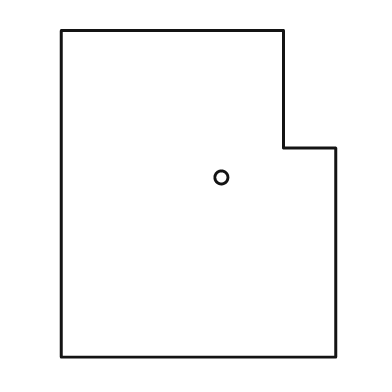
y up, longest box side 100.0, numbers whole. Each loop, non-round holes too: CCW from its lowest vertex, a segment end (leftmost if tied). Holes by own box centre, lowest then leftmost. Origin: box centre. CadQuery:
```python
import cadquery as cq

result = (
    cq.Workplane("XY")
    .moveTo(-42.0, -50.0)
    .lineTo(42.0, -50.0)
    .lineTo(42.0, 14.0)
    .lineTo(26.0, 14.0)
    .lineTo(26.0, 50.0)
    .lineTo(-42.0, 50.0)
    .close()
    .moveTo(7.0, 5.0)
    .circle(2.0)
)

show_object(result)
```